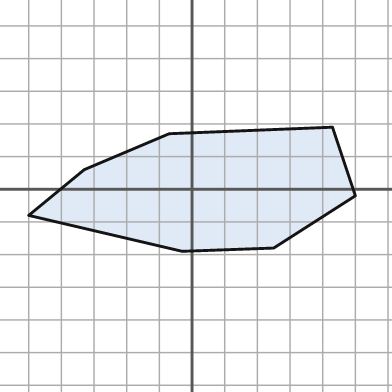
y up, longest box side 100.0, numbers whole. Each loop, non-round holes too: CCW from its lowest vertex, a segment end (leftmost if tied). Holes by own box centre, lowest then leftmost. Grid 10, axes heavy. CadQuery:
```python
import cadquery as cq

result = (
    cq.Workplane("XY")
    .moveTo(-3.0, -19.0)
    .lineTo(25.0, -18.0)
    .lineTo(50.0, -2.0)
    .lineTo(43.0, 19.0)
    .lineTo(-7.0, 17.0)
    .lineTo(-33.0, 6.0)
    .lineTo(-50.0, -8.0)
    .close()
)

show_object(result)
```